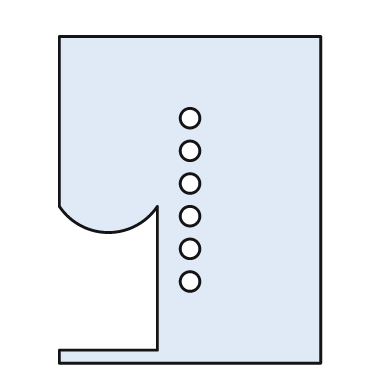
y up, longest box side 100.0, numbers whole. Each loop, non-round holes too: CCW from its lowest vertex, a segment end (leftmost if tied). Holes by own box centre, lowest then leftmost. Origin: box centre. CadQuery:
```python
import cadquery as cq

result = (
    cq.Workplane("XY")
    .moveTo(-40.0, -50.0)
    .lineTo(40.0, -50.0)
    .lineTo(40.0, 50.0)
    .lineTo(-40.0, 50.0)
    .lineTo(-40.0, -2.0)
    .threePointArc((-25.0, -10.0), (-10.0, -2.0))
    .lineTo(-10.0, -46.0)
    .lineTo(-40.0, -46.0)
    .close()
    .moveTo(0.0, -25.0)
    .circle(3.0)
    .moveTo(0.0, -15.0)
    .circle(3.0)
    .moveTo(0.0, -5.0)
    .circle(3.0)
    .moveTo(0.0, 5.0)
    .circle(3.0)
    .moveTo(0.0, 15.0)
    .circle(3.0)
    .moveTo(0.0, 25.0)
    .circle(3.0)
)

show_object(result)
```